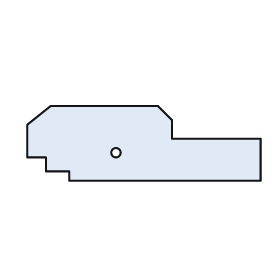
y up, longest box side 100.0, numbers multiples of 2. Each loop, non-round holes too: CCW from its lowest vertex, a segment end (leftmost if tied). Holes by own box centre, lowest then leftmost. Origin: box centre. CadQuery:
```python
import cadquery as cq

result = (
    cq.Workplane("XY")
    .moveTo(-32.0, -16.0)
    .lineTo(50.0, -16.0)
    .lineTo(50.0, 2.0)
    .lineTo(12.0, 2.0)
    .lineTo(12.0, 10.0)
    .lineTo(6.0, 16.0)
    .lineTo(-40.0, 16.0)
    .lineTo(-50.0, 8.0)
    .lineTo(-50.0, -6.0)
    .lineTo(-42.0, -6.0)
    .lineTo(-42.0, -12.0)
    .lineTo(-32.0, -12.0)
    .close()
    .moveTo(-12.0, -4.0)
    .circle(2.0)
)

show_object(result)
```